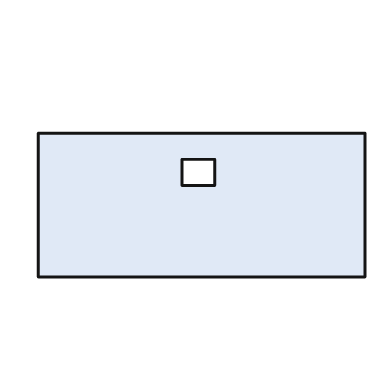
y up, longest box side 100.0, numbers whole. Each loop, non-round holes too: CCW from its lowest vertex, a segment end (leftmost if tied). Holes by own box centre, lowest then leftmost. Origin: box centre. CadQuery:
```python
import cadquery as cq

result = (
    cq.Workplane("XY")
    .moveTo(-50.0, -22.0)
    .lineTo(50.0, -22.0)
    .lineTo(50.0, 22.0)
    .lineTo(-50.0, 22.0)
    .close()
    .moveTo(-6.0, 6.0)
    .lineTo(4.0, 6.0)
    .lineTo(4.0, 14.0)
    .lineTo(-6.0, 14.0)
    .close()
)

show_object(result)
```